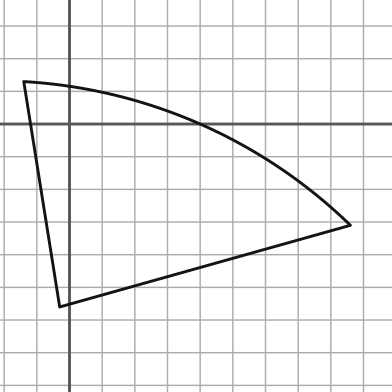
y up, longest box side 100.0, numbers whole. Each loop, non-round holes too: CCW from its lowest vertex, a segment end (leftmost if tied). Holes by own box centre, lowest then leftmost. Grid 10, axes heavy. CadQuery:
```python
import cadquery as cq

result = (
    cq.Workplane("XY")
    .moveTo(-3.0, -56.0)
    .lineTo(86.0, -31.0)
    .threePointArc((40.0, 0.0), (-14.0, 13.0))
    .close()
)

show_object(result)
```